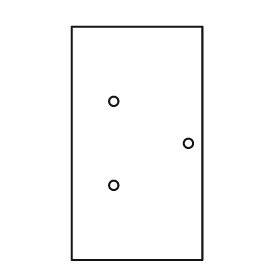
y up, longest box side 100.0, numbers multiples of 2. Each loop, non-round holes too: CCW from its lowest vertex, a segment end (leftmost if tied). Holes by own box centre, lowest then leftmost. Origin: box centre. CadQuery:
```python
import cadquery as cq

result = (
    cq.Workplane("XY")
    .moveTo(-28.0, -50.0)
    .lineTo(28.0, -50.0)
    .lineTo(28.0, 50.0)
    .lineTo(-28.0, 50.0)
    .close()
    .moveTo(-10.0, -18.0)
    .circle(2.0)
    .moveTo(22.0, 0.0)
    .circle(2.0)
    .moveTo(-10.0, 18.0)
    .circle(2.0)
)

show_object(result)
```